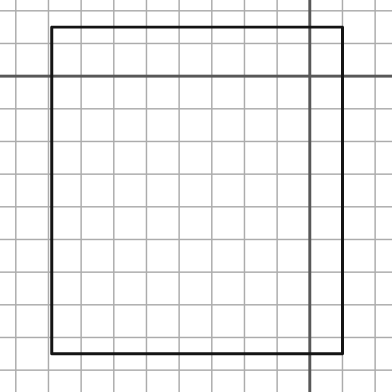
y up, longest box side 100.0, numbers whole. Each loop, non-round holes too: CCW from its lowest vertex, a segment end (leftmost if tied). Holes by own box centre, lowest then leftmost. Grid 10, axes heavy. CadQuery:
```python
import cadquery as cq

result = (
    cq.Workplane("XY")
    .moveTo(-79.0, -85.0)
    .lineTo(10.0, -85.0)
    .lineTo(10.0, 15.0)
    .lineTo(-79.0, 15.0)
    .close()
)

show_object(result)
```